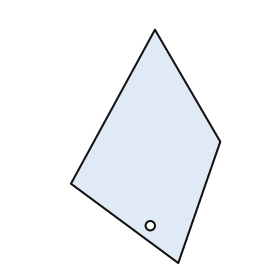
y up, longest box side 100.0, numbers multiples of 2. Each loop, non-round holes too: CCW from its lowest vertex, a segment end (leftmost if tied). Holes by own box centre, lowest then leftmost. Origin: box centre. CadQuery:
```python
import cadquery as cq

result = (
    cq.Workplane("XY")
    .moveTo(14.0, -50.0)
    .lineTo(32.0, 2.0)
    .lineTo(4.0, 50.0)
    .lineTo(-32.0, -16.0)
    .close()
    .moveTo(2.0, -34.0)
    .circle(2.0)
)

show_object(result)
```